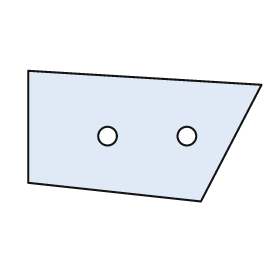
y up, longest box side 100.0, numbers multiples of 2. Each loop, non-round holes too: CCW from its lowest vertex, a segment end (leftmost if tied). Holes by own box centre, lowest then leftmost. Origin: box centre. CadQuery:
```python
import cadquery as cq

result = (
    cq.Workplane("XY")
    .moveTo(24.0, -28.0)
    .lineTo(50.0, 22.0)
    .lineTo(-50.0, 28.0)
    .lineTo(-50.0, -20.0)
    .close()
    .moveTo(-16.0, 0.0)
    .circle(4.0)
    .moveTo(18.0, 0.0)
    .circle(4.0)
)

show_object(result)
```